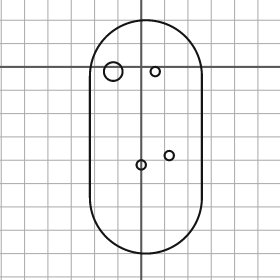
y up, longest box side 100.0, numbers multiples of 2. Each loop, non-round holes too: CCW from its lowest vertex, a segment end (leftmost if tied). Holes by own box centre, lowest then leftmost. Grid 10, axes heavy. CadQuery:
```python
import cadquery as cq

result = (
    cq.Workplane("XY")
    .moveTo(-22.0, -56.0)
    .threePointArc((2.0, -80.0), (26.0, -56.0))
    .lineTo(26.0, -4.0)
    .threePointArc((2.0, 20.0), (-22.0, -4.0))
    .close()
    .moveTo(0.0, -42.0)
    .circle(2.0)
    .moveTo(12.0, -38.0)
    .circle(2.0)
    .moveTo(-12.0, -2.0)
    .circle(4.0)
    .moveTo(6.0, -2.0)
    .circle(2.0)
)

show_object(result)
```